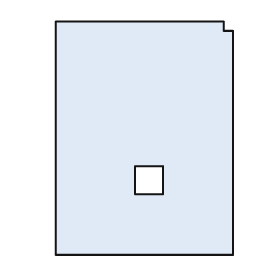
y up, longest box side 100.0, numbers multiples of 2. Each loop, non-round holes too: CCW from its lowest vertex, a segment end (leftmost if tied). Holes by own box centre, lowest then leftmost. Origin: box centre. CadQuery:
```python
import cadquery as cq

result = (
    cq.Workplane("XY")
    .moveTo(-38.0, -50.0)
    .lineTo(38.0, -50.0)
    .lineTo(38.0, 46.0)
    .lineTo(34.0, 46.0)
    .lineTo(34.0, 50.0)
    .lineTo(-38.0, 50.0)
    .close()
    .moveTo(-4.0, -24.0)
    .lineTo(8.0, -24.0)
    .lineTo(8.0, -12.0)
    .lineTo(-4.0, -12.0)
    .close()
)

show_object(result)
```